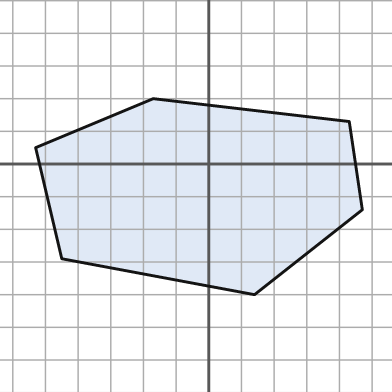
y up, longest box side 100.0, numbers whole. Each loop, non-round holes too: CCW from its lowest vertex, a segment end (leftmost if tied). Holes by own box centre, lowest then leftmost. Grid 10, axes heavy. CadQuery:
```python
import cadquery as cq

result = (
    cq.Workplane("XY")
    .moveTo(14.0, -40.0)
    .lineTo(47.0, -14.0)
    .lineTo(43.0, 13.0)
    .lineTo(-17.0, 20.0)
    .lineTo(-53.0, 5.0)
    .lineTo(-45.0, -29.0)
    .close()
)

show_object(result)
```